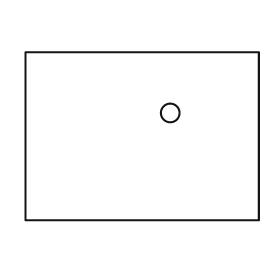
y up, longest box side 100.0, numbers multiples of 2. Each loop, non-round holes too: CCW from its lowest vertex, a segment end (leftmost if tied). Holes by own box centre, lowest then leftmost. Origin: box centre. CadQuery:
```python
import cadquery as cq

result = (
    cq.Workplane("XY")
    .moveTo(-50.0, -36.0)
    .lineTo(50.0, -36.0)
    .lineTo(50.0, 36.0)
    .lineTo(-50.0, 36.0)
    .close()
    .moveTo(12.0, 10.0)
    .circle(4.0)
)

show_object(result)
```